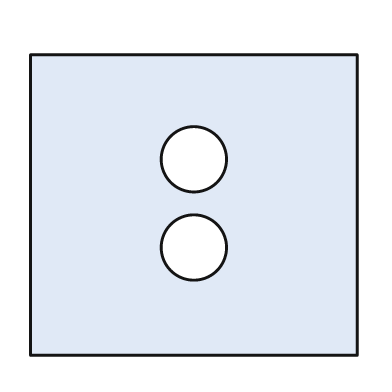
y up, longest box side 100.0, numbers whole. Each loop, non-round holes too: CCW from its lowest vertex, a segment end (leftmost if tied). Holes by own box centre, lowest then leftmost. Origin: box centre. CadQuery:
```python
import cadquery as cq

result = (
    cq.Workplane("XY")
    .moveTo(-50.0, -46.0)
    .lineTo(50.0, -46.0)
    .lineTo(50.0, 46.0)
    .lineTo(-50.0, 46.0)
    .close()
    .moveTo(0.0, -13.0)
    .circle(10.0)
    .moveTo(0.0, 14.0)
    .circle(10.0)
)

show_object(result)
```